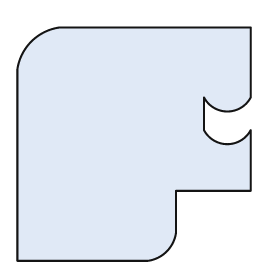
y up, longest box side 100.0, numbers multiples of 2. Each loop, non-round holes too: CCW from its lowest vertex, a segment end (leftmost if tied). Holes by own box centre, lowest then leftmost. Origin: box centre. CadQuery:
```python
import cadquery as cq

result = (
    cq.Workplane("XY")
    .moveTo(-50.0, -50.0)
    .lineTo(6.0, -50.0)
    .threePointArc((14.0, -46.0), (18.0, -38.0))
    .lineTo(18.0, -20.0)
    .lineTo(50.0, -20.0)
    .lineTo(50.0, 6.0)
    .threePointArc((40.0, 0.0), (30.0, 6.0))
    .lineTo(30.0, 20.0)
    .threePointArc((40.0, 14.0), (50.0, 20.0))
    .lineTo(50.0, 50.0)
    .lineTo(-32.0, 50.0)
    .threePointArc((-44.0, 44.0), (-50.0, 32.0))
    .close()
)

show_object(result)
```